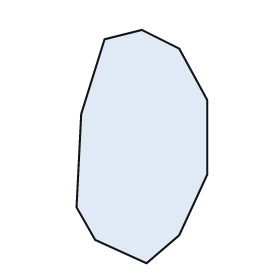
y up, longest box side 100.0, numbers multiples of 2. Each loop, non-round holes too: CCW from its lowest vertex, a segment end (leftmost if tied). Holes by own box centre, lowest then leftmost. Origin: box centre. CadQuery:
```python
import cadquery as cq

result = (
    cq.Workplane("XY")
    .moveTo(2.0, -50.0)
    .lineTo(16.0, -38.0)
    .lineTo(28.0, -12.0)
    .lineTo(28.0, 20.0)
    .lineTo(16.0, 42.0)
    .lineTo(0.0, 50.0)
    .lineTo(-16.0, 46.0)
    .lineTo(-26.0, 14.0)
    .lineTo(-28.0, -26.0)
    .lineTo(-20.0, -40.0)
    .close()
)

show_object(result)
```